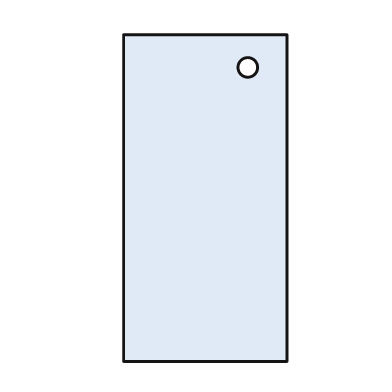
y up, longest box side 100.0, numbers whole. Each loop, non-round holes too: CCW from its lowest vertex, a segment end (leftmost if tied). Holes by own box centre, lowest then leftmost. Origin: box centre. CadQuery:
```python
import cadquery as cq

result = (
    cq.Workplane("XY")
    .moveTo(-25.0, -50.0)
    .lineTo(25.0, -50.0)
    .lineTo(25.0, 50.0)
    .lineTo(-25.0, 50.0)
    .close()
    .moveTo(13.0, 40.0)
    .circle(3.0)
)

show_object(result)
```